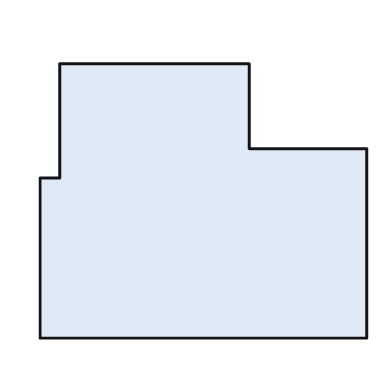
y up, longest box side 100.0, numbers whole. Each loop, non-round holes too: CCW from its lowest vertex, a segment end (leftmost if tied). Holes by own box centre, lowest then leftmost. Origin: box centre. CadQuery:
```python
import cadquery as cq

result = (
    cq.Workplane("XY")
    .moveTo(-50.0, -42.0)
    .lineTo(50.0, -42.0)
    .lineTo(50.0, 16.0)
    .lineTo(14.0, 16.0)
    .lineTo(14.0, 42.0)
    .lineTo(-44.0, 42.0)
    .lineTo(-44.0, 7.0)
    .lineTo(-50.0, 7.0)
    .close()
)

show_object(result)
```